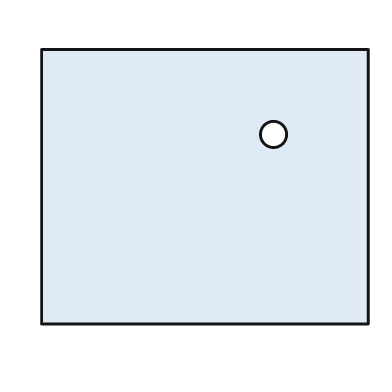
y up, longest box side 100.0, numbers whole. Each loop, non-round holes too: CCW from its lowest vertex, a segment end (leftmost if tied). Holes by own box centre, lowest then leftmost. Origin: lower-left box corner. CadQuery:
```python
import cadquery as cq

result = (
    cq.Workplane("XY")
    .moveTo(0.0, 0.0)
    .lineTo(100.0, 0.0)
    .lineTo(100.0, 84.0)
    .lineTo(0.0, 84.0)
    .close()
    .moveTo(71.0, 58.0)
    .circle(4.0)
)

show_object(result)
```